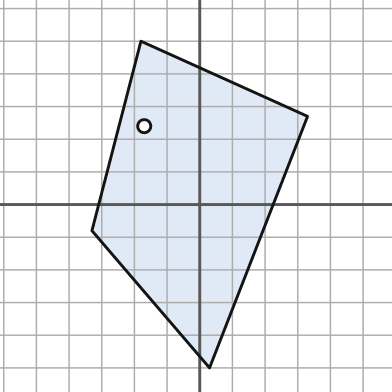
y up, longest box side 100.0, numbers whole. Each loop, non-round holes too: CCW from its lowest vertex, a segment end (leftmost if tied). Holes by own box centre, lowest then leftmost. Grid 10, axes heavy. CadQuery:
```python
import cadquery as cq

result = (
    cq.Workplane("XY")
    .moveTo(3.0, -50.0)
    .lineTo(33.0, 27.0)
    .lineTo(-18.0, 50.0)
    .lineTo(-33.0, -8.0)
    .close()
    .moveTo(-17.0, 24.0)
    .circle(2.0)
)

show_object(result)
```